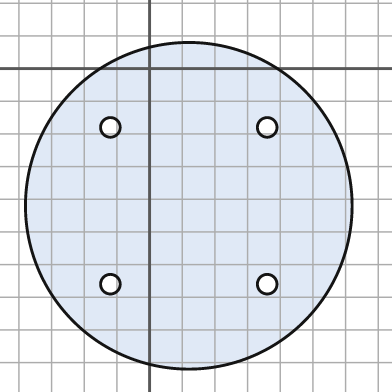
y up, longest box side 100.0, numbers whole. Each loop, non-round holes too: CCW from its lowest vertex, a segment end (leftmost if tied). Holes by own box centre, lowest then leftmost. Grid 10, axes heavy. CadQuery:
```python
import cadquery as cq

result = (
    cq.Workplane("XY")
    .moveTo(12.0, -42.0)
    .circle(50.0)
    .moveTo(-12.0, -66.0)
    .circle(3.0)
    .moveTo(36.0, -66.0)
    .circle(3.0)
    .moveTo(-12.0, -18.0)
    .circle(3.0)
    .moveTo(36.0, -18.0)
    .circle(3.0)
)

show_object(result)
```